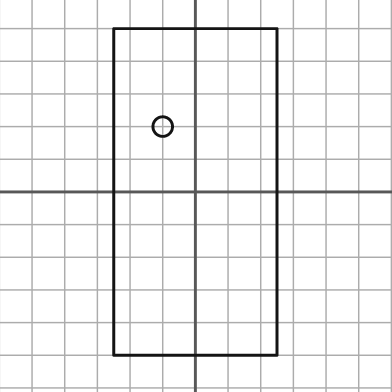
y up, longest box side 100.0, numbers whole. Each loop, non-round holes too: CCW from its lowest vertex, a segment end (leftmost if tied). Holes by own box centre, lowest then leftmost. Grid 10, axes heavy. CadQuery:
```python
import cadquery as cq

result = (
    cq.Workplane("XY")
    .moveTo(-25.0, -50.0)
    .lineTo(25.0, -50.0)
    .lineTo(25.0, 50.0)
    .lineTo(-25.0, 50.0)
    .close()
    .moveTo(-10.0, 20.0)
    .circle(3.0)
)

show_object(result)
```